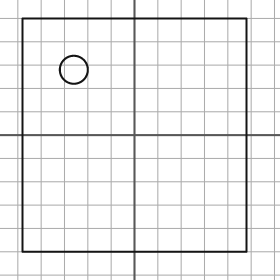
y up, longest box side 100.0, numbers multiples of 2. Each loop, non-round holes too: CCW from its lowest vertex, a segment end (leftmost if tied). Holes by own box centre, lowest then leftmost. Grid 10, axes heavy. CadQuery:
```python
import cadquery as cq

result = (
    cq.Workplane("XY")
    .moveTo(-48.0, -50.0)
    .lineTo(48.0, -50.0)
    .lineTo(48.0, 50.0)
    .lineTo(-48.0, 50.0)
    .close()
    .moveTo(-26.0, 28.0)
    .circle(6.0)
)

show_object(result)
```